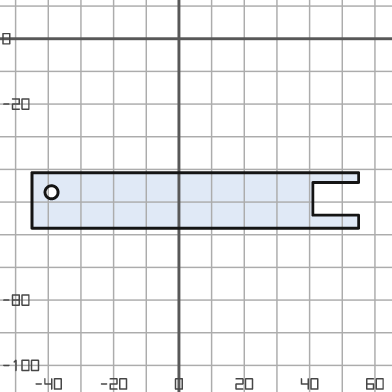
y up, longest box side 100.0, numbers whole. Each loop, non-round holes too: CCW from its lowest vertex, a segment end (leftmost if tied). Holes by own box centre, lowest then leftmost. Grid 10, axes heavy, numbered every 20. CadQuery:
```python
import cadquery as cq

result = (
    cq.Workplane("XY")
    .moveTo(-45.0, -58.0)
    .lineTo(55.0, -58.0)
    .lineTo(55.0, -54.0)
    .lineTo(41.0, -54.0)
    .lineTo(41.0, -44.0)
    .lineTo(55.0, -44.0)
    .lineTo(55.0, -41.0)
    .lineTo(-45.0, -41.0)
    .close()
    .moveTo(-39.0, -47.0)
    .circle(2.0)
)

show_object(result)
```